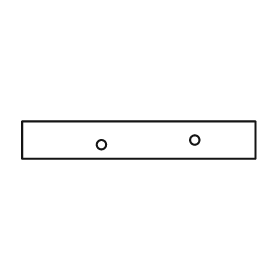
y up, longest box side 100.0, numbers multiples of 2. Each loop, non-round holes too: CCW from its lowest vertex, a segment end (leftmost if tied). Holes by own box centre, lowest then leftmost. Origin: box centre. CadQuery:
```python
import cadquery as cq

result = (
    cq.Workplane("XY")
    .moveTo(-50.0, -8.0)
    .lineTo(50.0, -8.0)
    .lineTo(50.0, 8.0)
    .lineTo(-50.0, 8.0)
    .close()
    .moveTo(-16.0, -2.0)
    .circle(2.0)
    .moveTo(24.0, 0.0)
    .circle(2.0)
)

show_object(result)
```